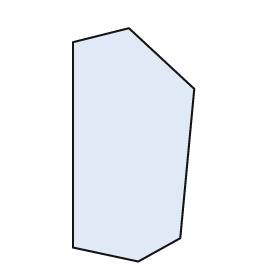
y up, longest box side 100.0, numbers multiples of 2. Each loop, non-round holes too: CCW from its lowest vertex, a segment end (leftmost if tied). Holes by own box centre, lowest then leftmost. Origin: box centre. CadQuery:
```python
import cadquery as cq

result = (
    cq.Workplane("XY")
    .moveTo(2.0, -50.0)
    .lineTo(20.0, -40.0)
    .lineTo(26.0, 24.0)
    .lineTo(-2.0, 50.0)
    .lineTo(-26.0, 44.0)
    .lineTo(-26.0, -44.0)
    .close()
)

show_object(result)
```